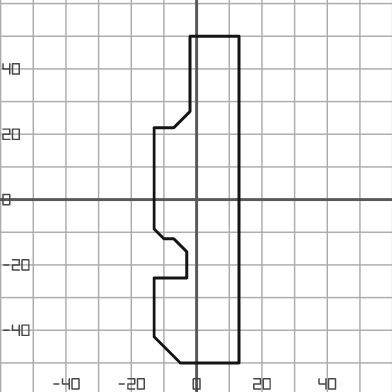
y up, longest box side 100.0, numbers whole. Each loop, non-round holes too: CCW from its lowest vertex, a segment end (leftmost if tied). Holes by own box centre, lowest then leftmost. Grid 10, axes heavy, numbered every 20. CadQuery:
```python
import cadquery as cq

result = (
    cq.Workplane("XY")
    .moveTo(-5.0, -50.0)
    .lineTo(13.0, -50.0)
    .lineTo(13.0, 50.0)
    .lineTo(-2.0, 50.0)
    .lineTo(-2.0, 27.0)
    .lineTo(-7.0, 22.0)
    .lineTo(-13.0, 22.0)
    .lineTo(-13.0, -9.0)
    .lineTo(-10.0, -12.0)
    .lineTo(-7.0, -12.0)
    .lineTo(-3.0, -16.0)
    .lineTo(-3.0, -24.0)
    .lineTo(-13.0, -24.0)
    .lineTo(-13.0, -42.0)
    .close()
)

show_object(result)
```